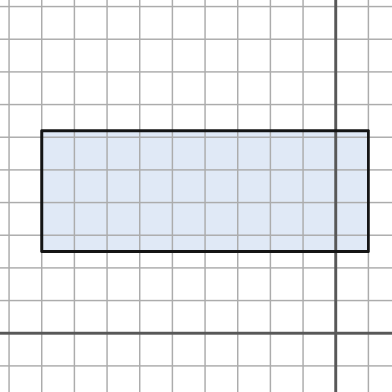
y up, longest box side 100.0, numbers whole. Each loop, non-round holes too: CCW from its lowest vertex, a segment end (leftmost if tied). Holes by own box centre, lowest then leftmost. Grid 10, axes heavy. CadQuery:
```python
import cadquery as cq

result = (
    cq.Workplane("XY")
    .moveTo(-90.0, 25.0)
    .lineTo(10.0, 25.0)
    .lineTo(10.0, 62.0)
    .lineTo(-90.0, 62.0)
    .close()
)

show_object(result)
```